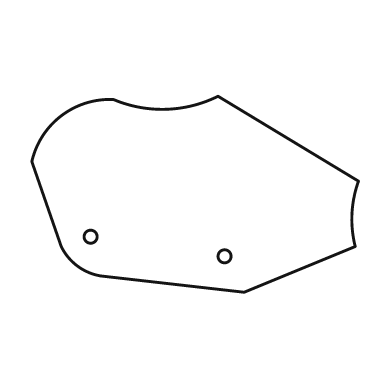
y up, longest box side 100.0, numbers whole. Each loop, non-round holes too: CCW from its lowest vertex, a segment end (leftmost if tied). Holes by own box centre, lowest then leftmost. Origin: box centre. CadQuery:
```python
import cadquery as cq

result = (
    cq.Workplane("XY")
    .moveTo(15.0, -30.0)
    .lineTo(49.0, -16.0)
    .threePointArc((48.0, -6.0), (50.0, 4.0))
    .lineTo(7.0, 30.0)
    .threePointArc((-9.0, 26.0), (-25.0, 29.0))
    .threePointArc((-41.0, 24.0), (-50.0, 10.0))
    .lineTo(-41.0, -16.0)
    .threePointArc((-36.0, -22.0), (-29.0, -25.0))
    .close()
    .moveTo(9.0, -19.0)
    .circle(2.0)
    .moveTo(-32.0, -13.0)
    .circle(2.0)
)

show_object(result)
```